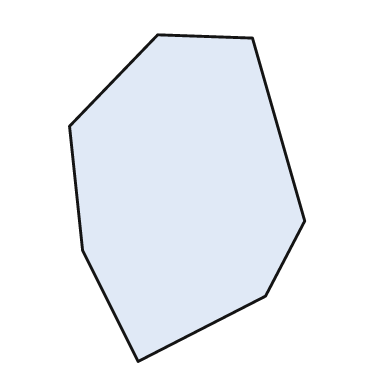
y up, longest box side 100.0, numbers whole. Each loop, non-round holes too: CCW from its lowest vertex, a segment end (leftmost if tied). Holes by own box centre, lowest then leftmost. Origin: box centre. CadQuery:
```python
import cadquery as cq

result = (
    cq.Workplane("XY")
    .moveTo(-15.0, -50.0)
    .lineTo(24.0, -30.0)
    .lineTo(36.0, -7.0)
    .lineTo(20.0, 49.0)
    .lineTo(-9.0, 50.0)
    .lineTo(-36.0, 22.0)
    .lineTo(-32.0, -16.0)
    .close()
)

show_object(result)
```